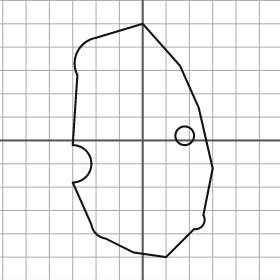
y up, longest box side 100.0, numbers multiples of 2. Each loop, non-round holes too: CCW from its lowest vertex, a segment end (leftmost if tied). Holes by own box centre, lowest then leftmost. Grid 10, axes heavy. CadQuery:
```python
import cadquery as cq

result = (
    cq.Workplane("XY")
    .moveTo(10.0, -50.0)
    .lineTo(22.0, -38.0)
    .threePointArc((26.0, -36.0), (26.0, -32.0))
    .lineTo(30.0, -12.0)
    .lineTo(24.0, 14.0)
    .lineTo(16.0, 32.0)
    .lineTo(0.0, 50.0)
    .lineTo(-20.0, 44.0)
    .threePointArc((-28.0, 38.0), (-28.0, 28.0))
    .lineTo(-30.0, -2.0)
    .threePointArc((-22.0, -10.0), (-30.0, -18.0))
    .lineTo(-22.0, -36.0)
    .threePointArc((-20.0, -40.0), (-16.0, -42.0))
    .lineTo(-4.0, -48.0)
    .close()
    .moveTo(18.0, 2.0)
    .circle(4.0)
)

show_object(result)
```